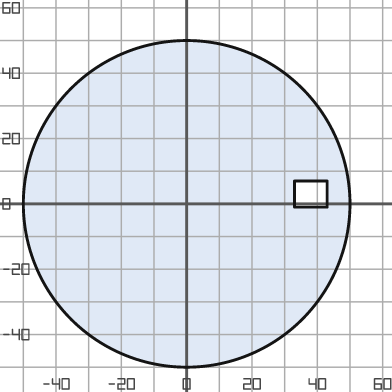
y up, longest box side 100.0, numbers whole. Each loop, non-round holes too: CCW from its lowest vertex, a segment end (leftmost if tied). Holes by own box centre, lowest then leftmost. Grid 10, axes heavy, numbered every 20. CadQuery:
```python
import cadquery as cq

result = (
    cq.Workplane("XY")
    .moveTo(0.0, 0.0)
    .circle(50.0)
    .moveTo(33.0, -1.0)
    .lineTo(43.0, -1.0)
    .lineTo(43.0, 7.0)
    .lineTo(33.0, 7.0)
    .close()
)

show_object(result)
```